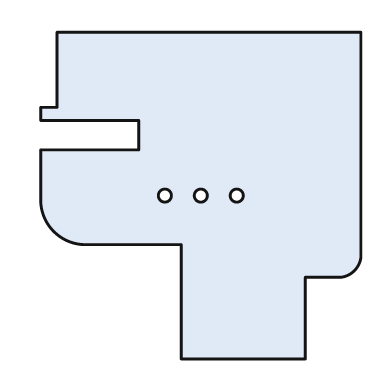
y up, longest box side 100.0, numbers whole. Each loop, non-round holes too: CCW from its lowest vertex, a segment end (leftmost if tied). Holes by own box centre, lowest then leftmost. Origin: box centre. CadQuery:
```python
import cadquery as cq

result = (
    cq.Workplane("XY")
    .moveTo(-6.0, -50.0)
    .lineTo(32.0, -50.0)
    .lineTo(32.0, -25.0)
    .lineTo(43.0, -25.0)
    .threePointArc((47.0, -23.0), (49.0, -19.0))
    .lineTo(49.0, 50.0)
    .lineTo(-44.0, 50.0)
    .lineTo(-44.0, 27.0)
    .lineTo(-49.0, 27.0)
    .lineTo(-49.0, 23.0)
    .lineTo(-19.0, 23.0)
    .lineTo(-19.0, 14.0)
    .lineTo(-49.0, 14.0)
    .lineTo(-49.0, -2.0)
    .threePointArc((-45.0, -11.0), (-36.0, -15.0))
    .lineTo(-6.0, -15.0)
    .close()
    .moveTo(-11.0, 0.0)
    .circle(2.0)
    .moveTo(0.0, 0.0)
    .circle(2.0)
    .moveTo(11.0, 0.0)
    .circle(2.0)
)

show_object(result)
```